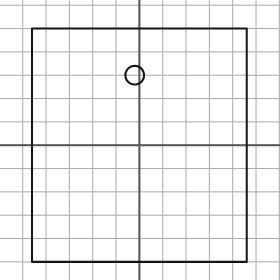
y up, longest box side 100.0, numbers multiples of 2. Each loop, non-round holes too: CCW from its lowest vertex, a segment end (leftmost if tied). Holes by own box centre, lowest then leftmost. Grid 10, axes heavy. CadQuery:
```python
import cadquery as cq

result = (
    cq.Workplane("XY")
    .moveTo(-46.0, -50.0)
    .lineTo(46.0, -50.0)
    .lineTo(46.0, 50.0)
    .lineTo(-46.0, 50.0)
    .close()
    .moveTo(-2.0, 30.0)
    .circle(4.0)
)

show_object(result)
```